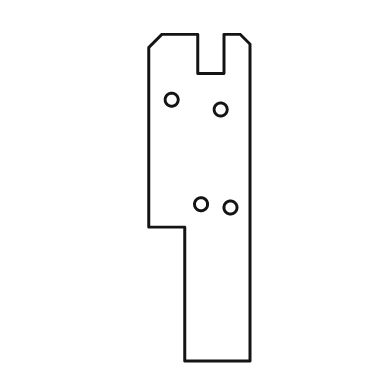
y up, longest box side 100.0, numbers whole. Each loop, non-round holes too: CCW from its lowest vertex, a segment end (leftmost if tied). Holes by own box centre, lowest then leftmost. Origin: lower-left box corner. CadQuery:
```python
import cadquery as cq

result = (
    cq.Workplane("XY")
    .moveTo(11.0, 0.0)
    .lineTo(31.0, 0.0)
    .lineTo(31.0, 97.0)
    .lineTo(28.0, 100.0)
    .lineTo(23.0, 100.0)
    .lineTo(23.0, 88.0)
    .lineTo(15.0, 88.0)
    .lineTo(15.0, 100.0)
    .lineTo(4.0, 100.0)
    .lineTo(0.0, 96.0)
    .lineTo(0.0, 41.0)
    .lineTo(11.0, 41.0)
    .close()
    .moveTo(25.0, 47.0)
    .circle(2.0)
    .moveTo(16.0, 48.0)
    .circle(2.0)
    .moveTo(22.0, 77.0)
    .circle(2.0)
    .moveTo(7.0, 80.0)
    .circle(2.0)
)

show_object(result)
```